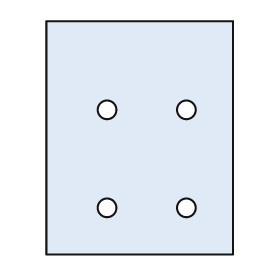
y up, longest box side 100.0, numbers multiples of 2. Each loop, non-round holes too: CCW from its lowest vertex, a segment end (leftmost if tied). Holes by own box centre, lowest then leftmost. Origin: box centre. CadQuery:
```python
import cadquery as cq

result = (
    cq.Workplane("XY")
    .moveTo(-40.0, -50.0)
    .lineTo(40.0, -50.0)
    .lineTo(40.0, 50.0)
    .lineTo(-40.0, 50.0)
    .close()
    .moveTo(-14.0, -30.0)
    .circle(4.0)
    .moveTo(20.0, -30.0)
    .circle(4.0)
    .moveTo(-14.0, 12.0)
    .circle(4.0)
    .moveTo(20.0, 12.0)
    .circle(4.0)
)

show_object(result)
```